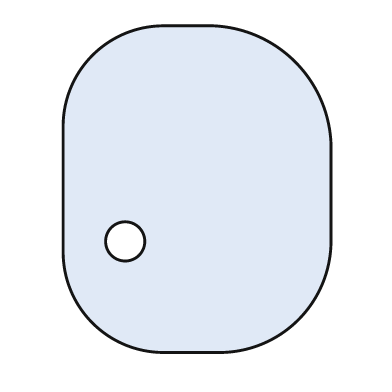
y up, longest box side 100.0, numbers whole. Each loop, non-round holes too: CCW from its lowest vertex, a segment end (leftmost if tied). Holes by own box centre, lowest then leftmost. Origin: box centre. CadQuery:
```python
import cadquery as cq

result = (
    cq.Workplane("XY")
    .moveTo(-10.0, -50.0)
    .lineTo(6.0, -50.0)
    .threePointArc((31.0, -40.0), (41.0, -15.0))
    .lineTo(41.0, 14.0)
    .threePointArc((30.0, 39.0), (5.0, 50.0))
    .lineTo(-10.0, 50.0)
    .threePointArc((-32.0, 41.0), (-41.0, 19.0))
    .lineTo(-41.0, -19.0)
    .threePointArc((-32.0, -41.0), (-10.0, -50.0))
    .close()
    .moveTo(-22.0, -16.0)
    .circle(6.0)
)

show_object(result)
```